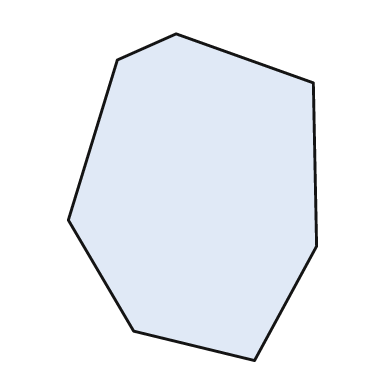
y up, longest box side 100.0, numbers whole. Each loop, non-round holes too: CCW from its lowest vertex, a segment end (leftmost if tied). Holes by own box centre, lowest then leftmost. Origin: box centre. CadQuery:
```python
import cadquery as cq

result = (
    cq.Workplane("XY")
    .moveTo(19.0, -50.0)
    .lineTo(38.0, -15.0)
    .lineTo(37.0, 35.0)
    .lineTo(-5.0, 50.0)
    .lineTo(-23.0, 42.0)
    .lineTo(-38.0, -7.0)
    .lineTo(-18.0, -41.0)
    .close()
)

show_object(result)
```